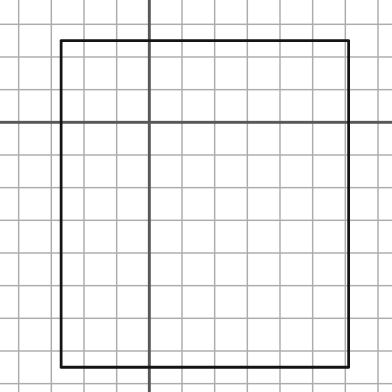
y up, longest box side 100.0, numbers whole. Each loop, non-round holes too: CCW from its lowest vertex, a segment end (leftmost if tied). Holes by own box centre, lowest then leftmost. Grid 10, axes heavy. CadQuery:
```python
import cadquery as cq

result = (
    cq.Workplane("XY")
    .moveTo(-27.0, -75.0)
    .lineTo(61.0, -75.0)
    .lineTo(61.0, 25.0)
    .lineTo(-27.0, 25.0)
    .close()
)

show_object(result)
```